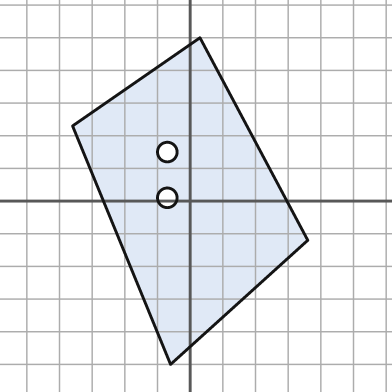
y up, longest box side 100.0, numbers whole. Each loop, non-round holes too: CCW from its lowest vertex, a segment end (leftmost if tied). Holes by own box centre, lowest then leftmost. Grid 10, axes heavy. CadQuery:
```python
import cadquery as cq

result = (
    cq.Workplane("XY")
    .moveTo(-6.0, -50.0)
    .lineTo(36.0, -12.0)
    .lineTo(3.0, 50.0)
    .lineTo(-36.0, 23.0)
    .close()
    .moveTo(-7.0, 1.0)
    .circle(3.0)
    .moveTo(-7.0, 15.0)
    .circle(3.0)
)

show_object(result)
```